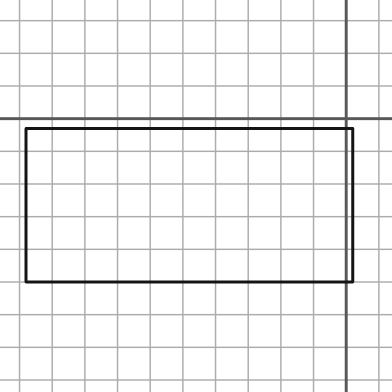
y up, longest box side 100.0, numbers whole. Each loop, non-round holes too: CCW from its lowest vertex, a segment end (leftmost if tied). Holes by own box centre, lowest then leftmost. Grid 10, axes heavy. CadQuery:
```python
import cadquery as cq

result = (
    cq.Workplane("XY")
    .moveTo(-98.0, -50.0)
    .lineTo(2.0, -50.0)
    .lineTo(2.0, -3.0)
    .lineTo(-98.0, -3.0)
    .close()
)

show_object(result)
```